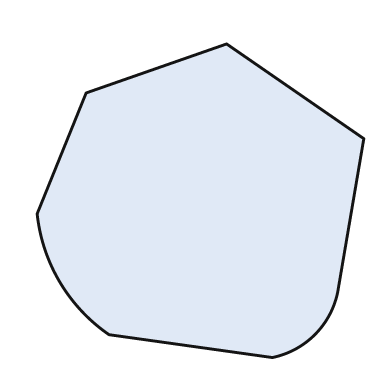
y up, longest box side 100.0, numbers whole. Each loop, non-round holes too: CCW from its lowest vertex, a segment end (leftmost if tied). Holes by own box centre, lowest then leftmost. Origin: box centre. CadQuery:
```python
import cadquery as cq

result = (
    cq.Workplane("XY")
    .moveTo(22.0, -48.0)
    .threePointArc((35.0, -41.0), (42.0, -28.0))
    .lineTo(50.0, 19.0)
    .lineTo(8.0, 48.0)
    .lineTo(-35.0, 33.0)
    .lineTo(-50.0, -4.0)
    .threePointArc((-43.0, -25.0), (-28.0, -41.0))
    .close()
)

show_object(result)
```